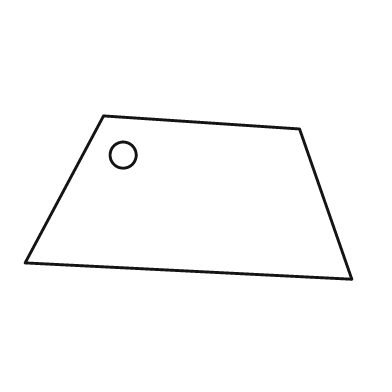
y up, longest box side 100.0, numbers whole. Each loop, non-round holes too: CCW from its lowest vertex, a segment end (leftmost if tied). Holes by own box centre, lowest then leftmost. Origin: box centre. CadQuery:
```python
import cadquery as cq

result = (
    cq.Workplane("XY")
    .moveTo(50.0, -25.0)
    .lineTo(34.0, 21.0)
    .lineTo(-26.0, 25.0)
    .lineTo(-50.0, -20.0)
    .close()
    .moveTo(-20.0, 13.0)
    .circle(4.0)
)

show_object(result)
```